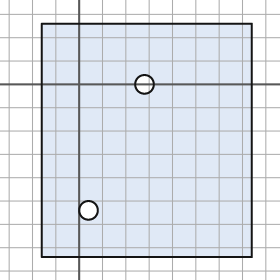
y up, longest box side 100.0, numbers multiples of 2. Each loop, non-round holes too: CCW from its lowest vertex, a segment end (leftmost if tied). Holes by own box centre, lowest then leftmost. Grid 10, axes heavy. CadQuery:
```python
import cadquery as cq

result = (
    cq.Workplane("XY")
    .moveTo(-16.0, -74.0)
    .lineTo(74.0, -74.0)
    .lineTo(74.0, 26.0)
    .lineTo(-16.0, 26.0)
    .close()
    .moveTo(4.0, -54.0)
    .circle(4.0)
    .moveTo(28.0, 0.0)
    .circle(4.0)
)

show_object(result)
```